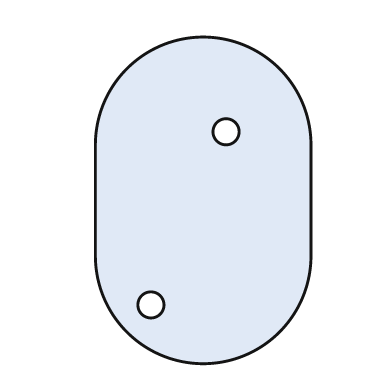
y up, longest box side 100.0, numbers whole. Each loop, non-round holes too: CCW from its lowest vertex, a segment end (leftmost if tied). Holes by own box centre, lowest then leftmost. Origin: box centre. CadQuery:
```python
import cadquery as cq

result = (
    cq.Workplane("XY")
    .moveTo(-33.0, -17.0)
    .threePointArc((0.0, -50.0), (33.0, -17.0))
    .lineTo(33.0, 17.0)
    .threePointArc((0.0, 50.0), (-33.0, 17.0))
    .close()
    .moveTo(-16.0, -32.0)
    .circle(4.0)
    .moveTo(7.0, 21.0)
    .circle(4.0)
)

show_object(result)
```